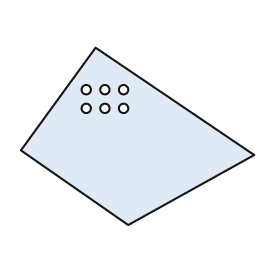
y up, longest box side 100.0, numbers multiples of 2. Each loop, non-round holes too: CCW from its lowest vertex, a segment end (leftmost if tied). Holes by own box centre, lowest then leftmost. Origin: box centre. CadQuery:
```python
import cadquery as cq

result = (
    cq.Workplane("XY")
    .moveTo(-4.0, -38.0)
    .lineTo(50.0, -8.0)
    .lineTo(-18.0, 38.0)
    .lineTo(-50.0, -6.0)
    .close()
    .moveTo(-22.0, 12.0)
    .circle(2.0)
    .moveTo(-14.0, 12.0)
    .circle(2.0)
    .moveTo(-6.0, 12.0)
    .circle(2.0)
    .moveTo(-22.0, 20.0)
    .circle(2.0)
    .moveTo(-14.0, 20.0)
    .circle(2.0)
    .moveTo(-6.0, 20.0)
    .circle(2.0)
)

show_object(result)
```